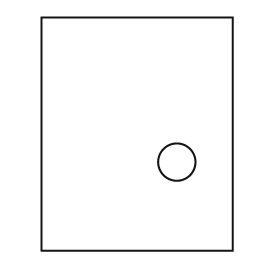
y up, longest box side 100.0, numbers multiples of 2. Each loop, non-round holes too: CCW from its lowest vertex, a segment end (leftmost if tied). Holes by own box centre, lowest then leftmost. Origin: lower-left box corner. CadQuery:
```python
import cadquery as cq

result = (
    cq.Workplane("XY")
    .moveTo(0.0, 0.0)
    .lineTo(82.0, 0.0)
    .lineTo(82.0, 100.0)
    .lineTo(0.0, 100.0)
    .close()
    .moveTo(58.0, 38.0)
    .circle(8.0)
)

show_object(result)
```